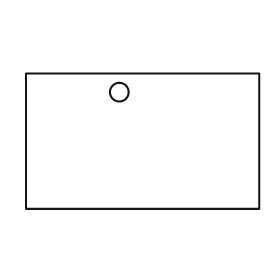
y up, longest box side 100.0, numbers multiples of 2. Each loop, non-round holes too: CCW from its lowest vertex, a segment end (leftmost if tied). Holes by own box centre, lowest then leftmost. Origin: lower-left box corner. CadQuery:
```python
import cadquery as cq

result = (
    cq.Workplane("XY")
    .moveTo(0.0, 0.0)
    .lineTo(100.0, 0.0)
    .lineTo(100.0, 58.0)
    .lineTo(0.0, 58.0)
    .close()
    .moveTo(40.0, 50.0)
    .circle(4.0)
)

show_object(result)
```